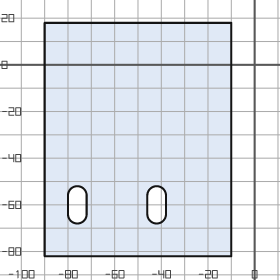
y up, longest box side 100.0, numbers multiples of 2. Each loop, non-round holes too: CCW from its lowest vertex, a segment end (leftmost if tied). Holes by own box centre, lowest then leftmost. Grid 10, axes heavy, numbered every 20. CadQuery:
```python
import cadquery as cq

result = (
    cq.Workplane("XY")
    .moveTo(-90.0, -82.0)
    .lineTo(-10.0, -82.0)
    .lineTo(-10.0, 18.0)
    .lineTo(-90.0, 18.0)
    .close()
    .moveTo(-80.0, -64.0)
    .threePointArc((-76.0, -68.0), (-72.0, -64.0))
    .lineTo(-72.0, -56.0)
    .threePointArc((-76.0, -52.0), (-80.0, -56.0))
    .close()
    .moveTo(-46.0, -64.0)
    .threePointArc((-42.0, -68.0), (-38.0, -64.0))
    .lineTo(-38.0, -56.0)
    .threePointArc((-42.0, -52.0), (-46.0, -56.0))
    .close()
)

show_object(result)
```